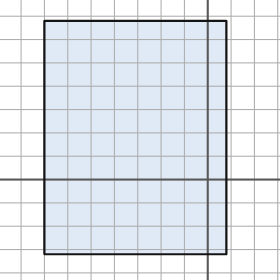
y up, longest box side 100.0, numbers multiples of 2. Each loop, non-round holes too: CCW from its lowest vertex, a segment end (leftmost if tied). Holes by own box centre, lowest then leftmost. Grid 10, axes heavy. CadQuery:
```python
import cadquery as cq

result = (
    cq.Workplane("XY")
    .moveTo(-70.0, -32.0)
    .lineTo(8.0, -32.0)
    .lineTo(8.0, 68.0)
    .lineTo(-70.0, 68.0)
    .close()
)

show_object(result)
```